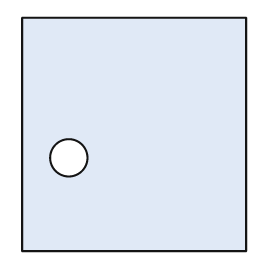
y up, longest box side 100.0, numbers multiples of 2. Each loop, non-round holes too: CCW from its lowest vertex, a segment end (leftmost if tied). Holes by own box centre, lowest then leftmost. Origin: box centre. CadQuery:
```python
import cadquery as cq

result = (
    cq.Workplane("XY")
    .moveTo(-48.0, -50.0)
    .lineTo(48.0, -50.0)
    .lineTo(48.0, 50.0)
    .lineTo(-48.0, 50.0)
    .close()
    .moveTo(-28.0, -10.0)
    .circle(8.0)
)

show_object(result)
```